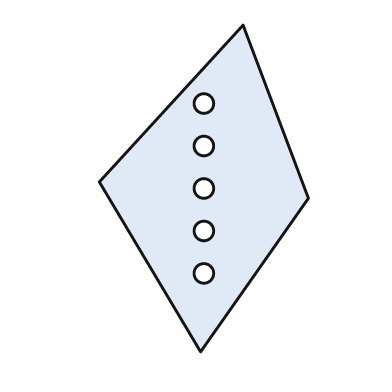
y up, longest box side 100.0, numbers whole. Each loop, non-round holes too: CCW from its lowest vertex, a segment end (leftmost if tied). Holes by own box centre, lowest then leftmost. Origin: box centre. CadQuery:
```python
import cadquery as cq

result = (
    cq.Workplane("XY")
    .moveTo(-1.0, -50.0)
    .lineTo(32.0, -3.0)
    .lineTo(12.0, 50.0)
    .lineTo(-32.0, 2.0)
    .close()
    .moveTo(0.0, -26.0)
    .circle(3.0)
    .moveTo(0.0, -13.0)
    .circle(3.0)
    .moveTo(0.0, 0.0)
    .circle(3.0)
    .moveTo(0.0, 13.0)
    .circle(3.0)
    .moveTo(0.0, 26.0)
    .circle(3.0)
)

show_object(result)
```